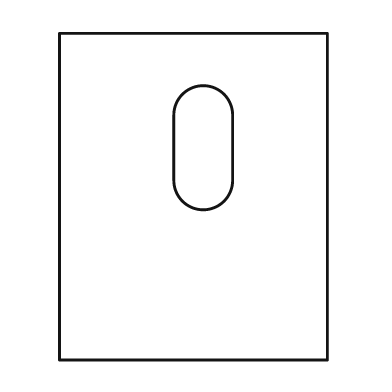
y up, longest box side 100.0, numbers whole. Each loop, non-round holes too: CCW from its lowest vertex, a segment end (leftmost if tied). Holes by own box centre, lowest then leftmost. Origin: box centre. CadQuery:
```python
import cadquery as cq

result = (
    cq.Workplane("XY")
    .moveTo(-41.0, -50.0)
    .lineTo(41.0, -50.0)
    .lineTo(41.0, 50.0)
    .lineTo(-41.0, 50.0)
    .close()
    .moveTo(-6.0, 5.0)
    .threePointArc((3.0, -4.0), (12.0, 5.0))
    .lineTo(12.0, 25.0)
    .threePointArc((3.0, 34.0), (-6.0, 25.0))
    .close()
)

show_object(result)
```